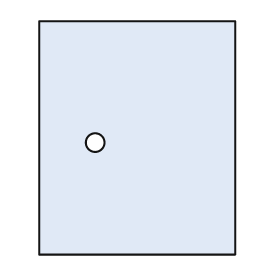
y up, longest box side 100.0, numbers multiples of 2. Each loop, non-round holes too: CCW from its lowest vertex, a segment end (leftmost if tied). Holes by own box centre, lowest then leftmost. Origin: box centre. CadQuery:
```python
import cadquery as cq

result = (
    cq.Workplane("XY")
    .moveTo(-42.0, -50.0)
    .lineTo(42.0, -50.0)
    .lineTo(42.0, 50.0)
    .lineTo(-42.0, 50.0)
    .close()
    .moveTo(-18.0, -2.0)
    .circle(4.0)
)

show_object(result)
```